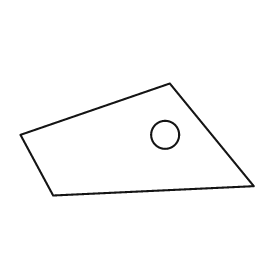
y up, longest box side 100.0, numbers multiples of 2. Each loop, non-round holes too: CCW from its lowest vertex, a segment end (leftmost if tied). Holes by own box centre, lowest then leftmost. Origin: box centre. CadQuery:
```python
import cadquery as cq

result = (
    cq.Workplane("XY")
    .moveTo(-36.0, -24.0)
    .lineTo(50.0, -20.0)
    .lineTo(14.0, 24.0)
    .lineTo(-50.0, 2.0)
    .close()
    .moveTo(12.0, 2.0)
    .circle(6.0)
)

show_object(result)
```